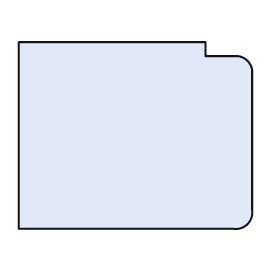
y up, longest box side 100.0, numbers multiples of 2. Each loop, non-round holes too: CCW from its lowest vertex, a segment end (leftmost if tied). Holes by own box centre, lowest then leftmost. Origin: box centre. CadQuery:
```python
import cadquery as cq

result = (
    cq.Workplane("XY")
    .moveTo(-50.0, -40.0)
    .lineTo(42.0, -40.0)
    .threePointArc((48.0, -38.0), (50.0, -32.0))
    .lineTo(50.0, 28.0)
    .threePointArc((48.0, 32.0), (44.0, 34.0))
    .lineTo(30.0, 34.0)
    .lineTo(30.0, 40.0)
    .lineTo(-50.0, 40.0)
    .close()
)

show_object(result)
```